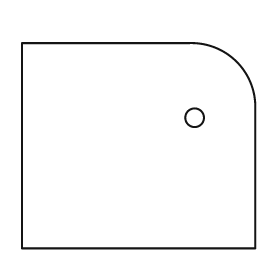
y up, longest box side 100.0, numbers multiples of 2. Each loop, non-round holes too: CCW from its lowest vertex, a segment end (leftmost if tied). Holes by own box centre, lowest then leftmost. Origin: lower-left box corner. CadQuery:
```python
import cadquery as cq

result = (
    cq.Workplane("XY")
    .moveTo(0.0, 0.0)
    .lineTo(100.0, 0.0)
    .lineTo(100.0, 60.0)
    .threePointArc((92.0, 80.0), (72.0, 88.0))
    .lineTo(0.0, 88.0)
    .close()
    .moveTo(74.0, 56.0)
    .circle(4.0)
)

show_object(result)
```